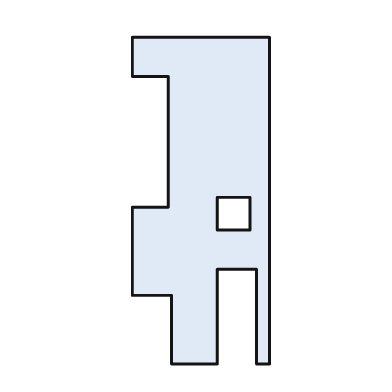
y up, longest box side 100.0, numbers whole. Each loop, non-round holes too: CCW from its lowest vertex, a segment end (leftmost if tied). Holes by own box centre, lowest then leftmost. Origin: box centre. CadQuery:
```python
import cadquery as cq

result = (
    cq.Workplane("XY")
    .moveTo(-9.0, -50.0)
    .lineTo(5.0, -50.0)
    .lineTo(5.0, -21.0)
    .lineTo(17.0, -21.0)
    .lineTo(17.0, -50.0)
    .lineTo(21.0, -50.0)
    .lineTo(21.0, 50.0)
    .lineTo(-21.0, 50.0)
    .lineTo(-21.0, 38.0)
    .lineTo(-10.0, 38.0)
    .lineTo(-10.0, -2.0)
    .lineTo(-21.0, -2.0)
    .lineTo(-21.0, -29.0)
    .lineTo(-9.0, -29.0)
    .close()
    .moveTo(5.0, -9.0)
    .lineTo(15.0, -9.0)
    .lineTo(15.0, 1.0)
    .lineTo(5.0, 1.0)
    .close()
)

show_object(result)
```